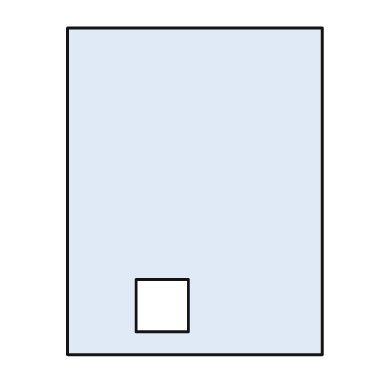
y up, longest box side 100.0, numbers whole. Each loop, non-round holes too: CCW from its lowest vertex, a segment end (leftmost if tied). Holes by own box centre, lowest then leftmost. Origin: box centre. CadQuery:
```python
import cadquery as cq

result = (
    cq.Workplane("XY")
    .moveTo(-39.0, -50.0)
    .lineTo(39.0, -50.0)
    .lineTo(39.0, 50.0)
    .lineTo(-39.0, 50.0)
    .close()
    .moveTo(-18.0, -43.0)
    .lineTo(-2.0, -43.0)
    .lineTo(-2.0, -27.0)
    .lineTo(-18.0, -27.0)
    .close()
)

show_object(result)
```